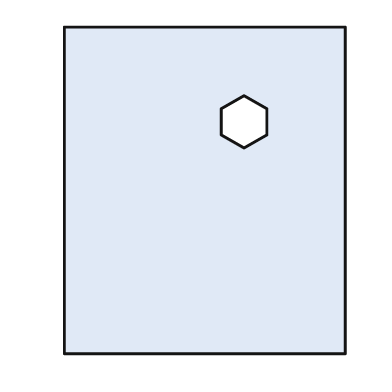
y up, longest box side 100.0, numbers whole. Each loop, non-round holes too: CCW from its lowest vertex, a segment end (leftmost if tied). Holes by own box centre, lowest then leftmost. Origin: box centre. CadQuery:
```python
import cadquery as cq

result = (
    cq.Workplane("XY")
    .moveTo(-43.0, -50.0)
    .lineTo(43.0, -50.0)
    .lineTo(43.0, 50.0)
    .lineTo(-43.0, 50.0)
    .close()
    .moveTo(12.0, 13.0)
    .lineTo(19.0, 17.0)
    .lineTo(19.0, 25.0)
    .lineTo(12.0, 29.0)
    .lineTo(5.0, 25.0)
    .lineTo(5.0, 17.0)
    .close()
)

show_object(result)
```